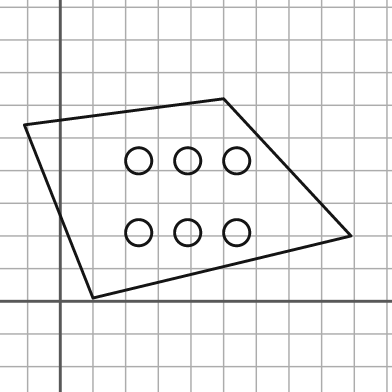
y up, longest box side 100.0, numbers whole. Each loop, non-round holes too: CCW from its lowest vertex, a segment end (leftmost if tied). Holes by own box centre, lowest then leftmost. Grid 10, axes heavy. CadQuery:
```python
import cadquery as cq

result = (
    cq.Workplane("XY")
    .moveTo(10.0, 1.0)
    .lineTo(89.0, 20.0)
    .lineTo(50.0, 62.0)
    .lineTo(-11.0, 54.0)
    .close()
    .moveTo(24.0, 21.0)
    .circle(4.0)
    .moveTo(39.0, 21.0)
    .circle(4.0)
    .moveTo(54.0, 21.0)
    .circle(4.0)
    .moveTo(24.0, 43.0)
    .circle(4.0)
    .moveTo(39.0, 43.0)
    .circle(4.0)
    .moveTo(54.0, 43.0)
    .circle(4.0)
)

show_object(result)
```